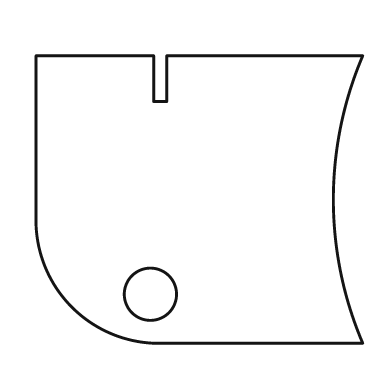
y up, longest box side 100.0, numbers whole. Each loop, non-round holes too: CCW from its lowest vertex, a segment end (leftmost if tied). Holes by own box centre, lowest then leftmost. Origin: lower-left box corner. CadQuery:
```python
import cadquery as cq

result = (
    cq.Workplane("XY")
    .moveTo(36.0, 0.0)
    .lineTo(100.0, 0.0)
    .threePointArc((91.0, 44.0), (100.0, 88.0))
    .lineTo(40.0, 88.0)
    .lineTo(40.0, 74.0)
    .lineTo(36.0, 74.0)
    .lineTo(36.0, 88.0)
    .lineTo(0.0, 88.0)
    .lineTo(0.0, 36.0)
    .threePointArc((11.0, 11.0), (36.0, 0.0))
    .close()
    .moveTo(35.0, 15.0)
    .circle(8.0)
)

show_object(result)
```